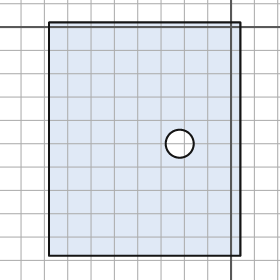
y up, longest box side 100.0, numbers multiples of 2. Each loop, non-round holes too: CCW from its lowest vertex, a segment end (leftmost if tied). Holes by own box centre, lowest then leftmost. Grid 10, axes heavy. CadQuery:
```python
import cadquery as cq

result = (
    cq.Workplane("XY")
    .moveTo(-78.0, -98.0)
    .lineTo(4.0, -98.0)
    .lineTo(4.0, 2.0)
    .lineTo(-78.0, 2.0)
    .close()
    .moveTo(-22.0, -50.0)
    .circle(6.0)
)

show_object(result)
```